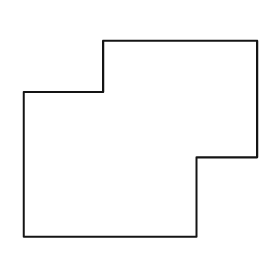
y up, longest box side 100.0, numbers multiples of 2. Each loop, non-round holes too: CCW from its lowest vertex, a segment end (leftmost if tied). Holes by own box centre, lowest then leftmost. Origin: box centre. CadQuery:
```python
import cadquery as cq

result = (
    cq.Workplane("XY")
    .moveTo(-50.0, -42.0)
    .lineTo(24.0, -42.0)
    .lineTo(24.0, -8.0)
    .lineTo(50.0, -8.0)
    .lineTo(50.0, 42.0)
    .lineTo(-16.0, 42.0)
    .lineTo(-16.0, 20.0)
    .lineTo(-50.0, 20.0)
    .close()
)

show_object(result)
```